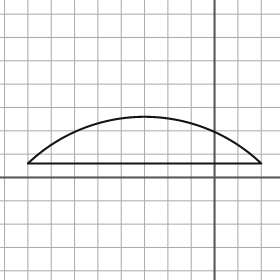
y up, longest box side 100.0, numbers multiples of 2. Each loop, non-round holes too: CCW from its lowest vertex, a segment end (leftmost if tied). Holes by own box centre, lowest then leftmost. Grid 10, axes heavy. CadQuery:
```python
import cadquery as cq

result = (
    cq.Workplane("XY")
    .moveTo(-80.0, 6.0)
    .lineTo(20.0, 6.0)
    .threePointArc((-30.0, 26.0), (-80.0, 6.0))
    .close()
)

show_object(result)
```